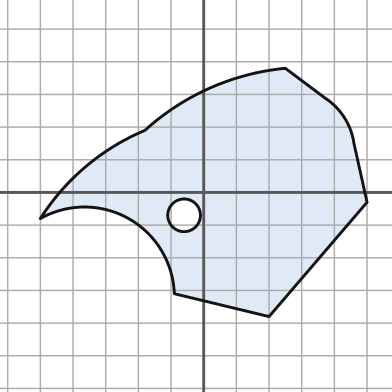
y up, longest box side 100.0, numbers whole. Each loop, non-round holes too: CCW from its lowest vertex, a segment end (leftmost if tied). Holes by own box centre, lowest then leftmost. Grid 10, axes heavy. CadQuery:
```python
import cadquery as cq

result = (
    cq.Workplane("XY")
    .moveTo(20.0, -38.0)
    .lineTo(50.0, -3.0)
    .lineTo(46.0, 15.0)
    .threePointArc((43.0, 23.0), (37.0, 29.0))
    .lineTo(25.0, 38.0)
    .threePointArc((2.0, 32.0), (-18.0, 19.0))
    .threePointArc((-36.0, 8.0), (-50.0, -8.0))
    .threePointArc((-23.0, -8.0), (-9.0, -31.0))
    .close()
    .moveTo(-6.0, -7.0)
    .circle(5.0)
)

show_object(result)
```